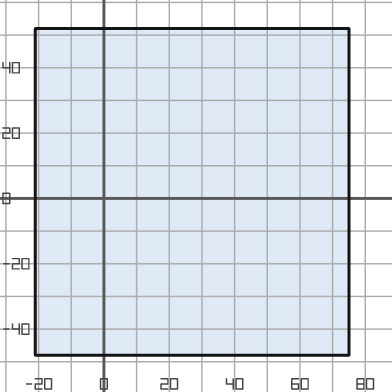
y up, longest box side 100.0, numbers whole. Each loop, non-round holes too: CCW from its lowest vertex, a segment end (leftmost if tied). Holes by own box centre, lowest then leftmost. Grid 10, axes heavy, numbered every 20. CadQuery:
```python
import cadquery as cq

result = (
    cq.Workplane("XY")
    .moveTo(-21.0, -48.0)
    .lineTo(75.0, -48.0)
    .lineTo(75.0, 52.0)
    .lineTo(-21.0, 52.0)
    .close()
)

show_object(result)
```